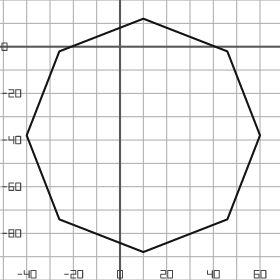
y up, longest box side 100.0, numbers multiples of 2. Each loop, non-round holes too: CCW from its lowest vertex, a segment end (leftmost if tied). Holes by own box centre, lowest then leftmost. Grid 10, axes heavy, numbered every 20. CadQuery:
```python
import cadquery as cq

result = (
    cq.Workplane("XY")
    .moveTo(10.0, -88.0)
    .lineTo(46.0, -74.0)
    .lineTo(60.0, -38.0)
    .lineTo(46.0, -2.0)
    .lineTo(10.0, 12.0)
    .lineTo(-26.0, -2.0)
    .lineTo(-40.0, -38.0)
    .lineTo(-26.0, -74.0)
    .close()
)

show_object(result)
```